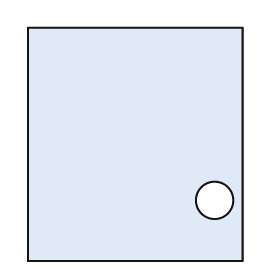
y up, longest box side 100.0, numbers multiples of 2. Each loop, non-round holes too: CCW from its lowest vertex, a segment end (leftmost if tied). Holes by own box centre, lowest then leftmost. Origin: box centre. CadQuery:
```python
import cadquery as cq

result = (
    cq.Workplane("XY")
    .moveTo(-46.0, -50.0)
    .lineTo(46.0, -50.0)
    .lineTo(46.0, 50.0)
    .lineTo(-46.0, 50.0)
    .close()
    .moveTo(34.0, -24.0)
    .circle(8.0)
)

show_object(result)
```